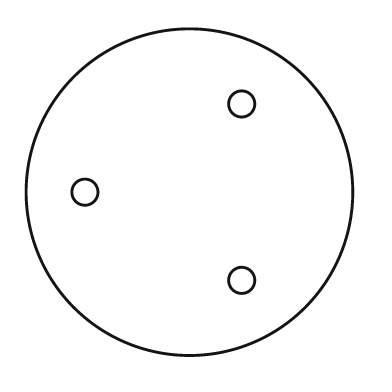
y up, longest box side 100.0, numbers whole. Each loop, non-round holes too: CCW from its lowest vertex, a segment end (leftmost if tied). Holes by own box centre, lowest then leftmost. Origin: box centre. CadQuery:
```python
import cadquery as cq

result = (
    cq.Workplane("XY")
    .moveTo(0.0, 0.0)
    .circle(50.0)
    .moveTo(16.0, -27.0)
    .circle(4.0)
    .moveTo(-32.0, 0.0)
    .circle(4.0)
    .moveTo(16.0, 27.0)
    .circle(4.0)
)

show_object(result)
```